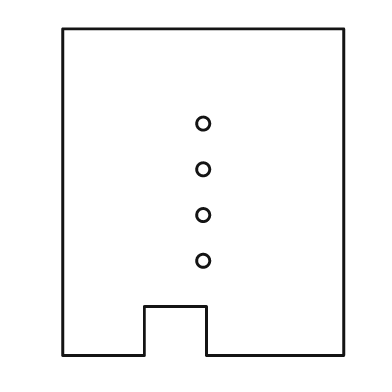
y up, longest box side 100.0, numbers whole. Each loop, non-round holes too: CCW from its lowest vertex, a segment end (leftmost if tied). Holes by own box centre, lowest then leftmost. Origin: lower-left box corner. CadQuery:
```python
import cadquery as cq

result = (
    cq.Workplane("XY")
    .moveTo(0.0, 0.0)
    .lineTo(25.0, 0.0)
    .lineTo(25.0, 15.0)
    .lineTo(44.0, 15.0)
    .lineTo(44.0, 0.0)
    .lineTo(86.0, 0.0)
    .lineTo(86.0, 100.0)
    .lineTo(0.0, 100.0)
    .close()
    .moveTo(43.0, 29.0)
    .circle(2.0)
    .moveTo(43.0, 43.0)
    .circle(2.0)
    .moveTo(43.0, 57.0)
    .circle(2.0)
    .moveTo(43.0, 71.0)
    .circle(2.0)
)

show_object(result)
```